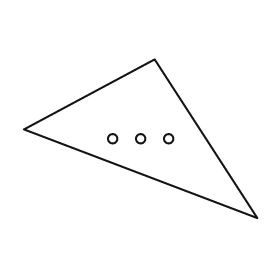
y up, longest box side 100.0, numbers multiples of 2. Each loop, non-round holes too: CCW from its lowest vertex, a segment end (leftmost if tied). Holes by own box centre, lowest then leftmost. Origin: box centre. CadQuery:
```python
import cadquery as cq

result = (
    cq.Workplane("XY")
    .moveTo(50.0, -34.0)
    .lineTo(6.0, 34.0)
    .lineTo(-50.0, 4.0)
    .close()
    .moveTo(-12.0, 0.0)
    .circle(2.0)
    .moveTo(0.0, 0.0)
    .circle(2.0)
    .moveTo(12.0, 0.0)
    .circle(2.0)
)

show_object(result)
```